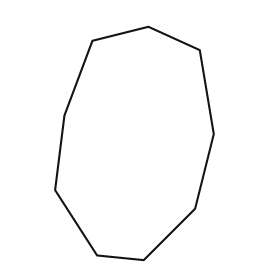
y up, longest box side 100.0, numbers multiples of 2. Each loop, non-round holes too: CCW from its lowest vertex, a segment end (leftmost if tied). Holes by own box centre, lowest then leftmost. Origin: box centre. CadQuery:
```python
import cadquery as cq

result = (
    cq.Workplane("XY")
    .moveTo(4.0, -50.0)
    .lineTo(26.0, -28.0)
    .lineTo(34.0, 4.0)
    .lineTo(28.0, 40.0)
    .lineTo(6.0, 50.0)
    .lineTo(-18.0, 44.0)
    .lineTo(-30.0, 12.0)
    .lineTo(-34.0, -20.0)
    .lineTo(-16.0, -48.0)
    .close()
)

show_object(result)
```